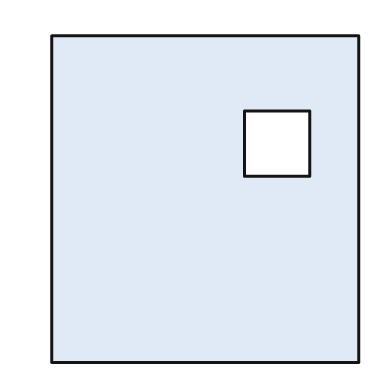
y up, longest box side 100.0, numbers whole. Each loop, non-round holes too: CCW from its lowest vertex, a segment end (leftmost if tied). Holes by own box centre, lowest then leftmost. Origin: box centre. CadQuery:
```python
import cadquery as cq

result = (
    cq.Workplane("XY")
    .moveTo(-47.0, -50.0)
    .lineTo(47.0, -50.0)
    .lineTo(47.0, 50.0)
    .lineTo(-47.0, 50.0)
    .close()
    .moveTo(12.0, 7.0)
    .lineTo(32.0, 7.0)
    .lineTo(32.0, 27.0)
    .lineTo(12.0, 27.0)
    .close()
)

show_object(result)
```